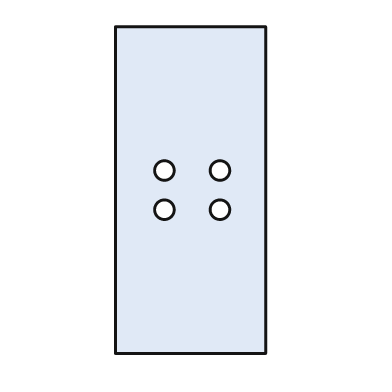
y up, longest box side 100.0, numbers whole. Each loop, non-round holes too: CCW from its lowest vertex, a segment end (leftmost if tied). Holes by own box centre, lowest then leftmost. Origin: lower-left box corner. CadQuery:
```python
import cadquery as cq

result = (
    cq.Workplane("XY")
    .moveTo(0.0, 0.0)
    .lineTo(46.0, 0.0)
    .lineTo(46.0, 100.0)
    .lineTo(0.0, 100.0)
    .close()
    .moveTo(15.0, 44.0)
    .circle(3.0)
    .moveTo(32.0, 44.0)
    .circle(3.0)
    .moveTo(15.0, 56.0)
    .circle(3.0)
    .moveTo(32.0, 56.0)
    .circle(3.0)
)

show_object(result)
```